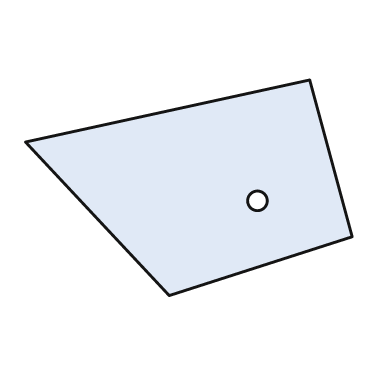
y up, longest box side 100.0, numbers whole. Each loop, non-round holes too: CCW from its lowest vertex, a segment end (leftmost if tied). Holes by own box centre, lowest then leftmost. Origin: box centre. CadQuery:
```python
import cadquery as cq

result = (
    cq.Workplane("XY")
    .moveTo(-6.0, -33.0)
    .lineTo(50.0, -15.0)
    .lineTo(37.0, 33.0)
    .lineTo(-50.0, 14.0)
    .close()
    .moveTo(21.0, -4.0)
    .circle(3.0)
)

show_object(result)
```